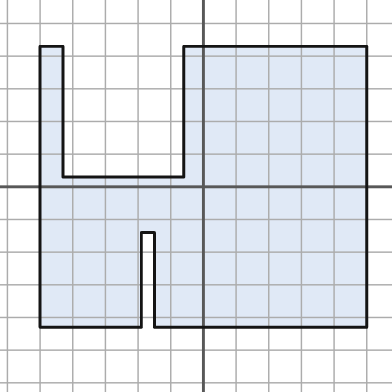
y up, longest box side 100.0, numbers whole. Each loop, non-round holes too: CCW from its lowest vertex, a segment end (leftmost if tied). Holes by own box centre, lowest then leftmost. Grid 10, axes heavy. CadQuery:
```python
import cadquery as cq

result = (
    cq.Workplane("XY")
    .moveTo(-50.0, -43.0)
    .lineTo(-19.0, -43.0)
    .lineTo(-19.0, -14.0)
    .lineTo(-15.0, -14.0)
    .lineTo(-15.0, -43.0)
    .lineTo(50.0, -43.0)
    .lineTo(50.0, 43.0)
    .lineTo(-6.0, 43.0)
    .lineTo(-6.0, 3.0)
    .lineTo(-43.0, 3.0)
    .lineTo(-43.0, 43.0)
    .lineTo(-50.0, 43.0)
    .close()
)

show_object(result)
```